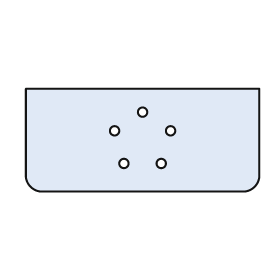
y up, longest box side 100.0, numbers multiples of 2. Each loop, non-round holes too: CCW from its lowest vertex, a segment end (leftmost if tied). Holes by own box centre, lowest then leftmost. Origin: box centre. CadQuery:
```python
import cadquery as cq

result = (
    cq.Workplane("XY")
    .moveTo(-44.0, -22.0)
    .lineTo(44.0, -22.0)
    .threePointArc((48.0, -20.0), (50.0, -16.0))
    .lineTo(50.0, 22.0)
    .lineTo(-50.0, 22.0)
    .lineTo(-50.0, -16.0)
    .threePointArc((-48.0, -20.0), (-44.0, -22.0))
    .close()
    .moveTo(-8.0, -10.0)
    .circle(2.0)
    .moveTo(8.0, -10.0)
    .circle(2.0)
    .moveTo(-12.0, 4.0)
    .circle(2.0)
    .moveTo(12.0, 4.0)
    .circle(2.0)
    .moveTo(0.0, 12.0)
    .circle(2.0)
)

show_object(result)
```